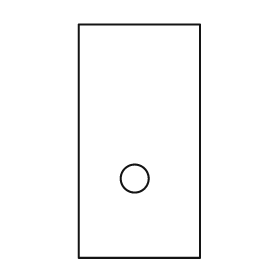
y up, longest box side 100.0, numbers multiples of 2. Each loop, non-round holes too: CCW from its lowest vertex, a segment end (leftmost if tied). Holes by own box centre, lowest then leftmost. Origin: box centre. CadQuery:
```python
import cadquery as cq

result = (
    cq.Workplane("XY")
    .moveTo(-26.0, -50.0)
    .lineTo(26.0, -50.0)
    .lineTo(26.0, 50.0)
    .lineTo(-26.0, 50.0)
    .close()
    .moveTo(-2.0, -16.0)
    .circle(6.0)
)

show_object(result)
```